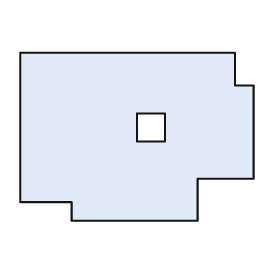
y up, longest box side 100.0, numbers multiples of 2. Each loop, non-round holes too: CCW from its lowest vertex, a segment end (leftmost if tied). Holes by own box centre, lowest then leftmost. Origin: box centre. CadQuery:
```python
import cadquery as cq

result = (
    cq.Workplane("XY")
    .moveTo(-28.0, -36.0)
    .lineTo(26.0, -36.0)
    .lineTo(26.0, -18.0)
    .lineTo(50.0, -18.0)
    .lineTo(50.0, 22.0)
    .lineTo(42.0, 22.0)
    .lineTo(42.0, 36.0)
    .lineTo(-50.0, 36.0)
    .lineTo(-50.0, -28.0)
    .lineTo(-28.0, -28.0)
    .close()
    .moveTo(0.0, -2.0)
    .lineTo(12.0, -2.0)
    .lineTo(12.0, 10.0)
    .lineTo(0.0, 10.0)
    .close()
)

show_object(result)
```